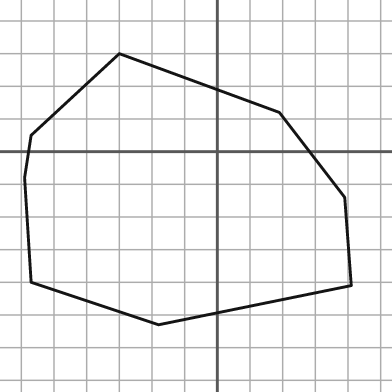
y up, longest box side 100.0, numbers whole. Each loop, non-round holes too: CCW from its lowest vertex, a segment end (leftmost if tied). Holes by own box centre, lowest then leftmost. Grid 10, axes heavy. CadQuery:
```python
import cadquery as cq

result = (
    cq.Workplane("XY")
    .moveTo(-18.0, -53.0)
    .lineTo(41.0, -41.0)
    .lineTo(39.0, -14.0)
    .lineTo(19.0, 12.0)
    .lineTo(-30.0, 30.0)
    .lineTo(-57.0, 5.0)
    .lineTo(-59.0, -8.0)
    .lineTo(-57.0, -40.0)
    .close()
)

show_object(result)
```